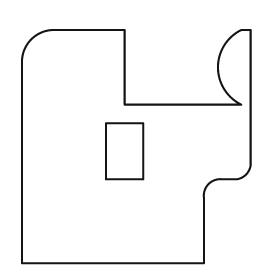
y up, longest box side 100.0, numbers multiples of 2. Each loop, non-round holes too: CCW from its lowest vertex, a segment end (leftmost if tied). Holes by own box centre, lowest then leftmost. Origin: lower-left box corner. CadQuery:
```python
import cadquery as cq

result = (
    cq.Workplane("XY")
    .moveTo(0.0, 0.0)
    .lineTo(78.0, 0.0)
    .lineTo(78.0, 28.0)
    .threePointArc((80.0, 34.0), (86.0, 36.0))
    .lineTo(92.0, 36.0)
    .threePointArc((96.0, 38.0), (98.0, 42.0))
    .lineTo(98.0, 100.0)
    .lineTo(94.0, 100.0)
    .threePointArc((84.0, 84.0), (94.0, 68.0))
    .lineTo(44.0, 68.0)
    .lineTo(44.0, 100.0)
    .lineTo(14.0, 100.0)
    .threePointArc((4.0, 96.0), (0.0, 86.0))
    .close()
    .moveTo(36.0, 36.0)
    .lineTo(52.0, 36.0)
    .lineTo(52.0, 60.0)
    .lineTo(36.0, 60.0)
    .close()
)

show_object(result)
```